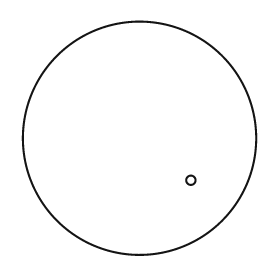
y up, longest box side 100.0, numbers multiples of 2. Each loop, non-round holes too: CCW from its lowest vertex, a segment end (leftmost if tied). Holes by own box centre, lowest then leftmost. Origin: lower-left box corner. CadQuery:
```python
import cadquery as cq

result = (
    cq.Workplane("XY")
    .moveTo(50.0, 50.0)
    .circle(50.0)
    .moveTo(72.0, 32.0)
    .circle(2.0)
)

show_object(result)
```